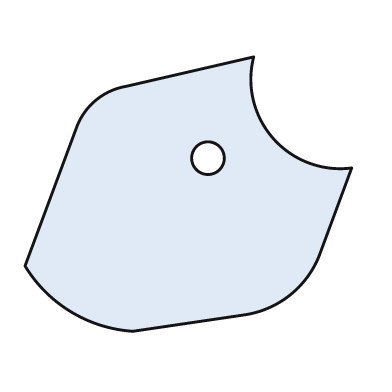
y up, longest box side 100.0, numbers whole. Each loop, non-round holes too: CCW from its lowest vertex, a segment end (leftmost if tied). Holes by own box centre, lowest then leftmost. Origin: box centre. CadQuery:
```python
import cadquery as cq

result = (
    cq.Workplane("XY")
    .moveTo(-17.0, -42.0)
    .lineTo(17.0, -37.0)
    .threePointArc((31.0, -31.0), (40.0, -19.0))
    .lineTo(50.0, 8.0)
    .threePointArc((26.0, 17.0), (20.0, 42.0))
    .lineTo(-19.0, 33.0)
    .threePointArc((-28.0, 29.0), (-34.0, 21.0))
    .lineTo(-50.0, -22.0)
    .threePointArc((-36.0, -36.0), (-17.0, -42.0))
    .close()
    .moveTo(6.0, 11.0)
    .circle(5.0)
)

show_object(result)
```